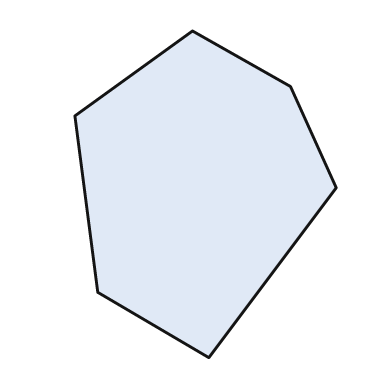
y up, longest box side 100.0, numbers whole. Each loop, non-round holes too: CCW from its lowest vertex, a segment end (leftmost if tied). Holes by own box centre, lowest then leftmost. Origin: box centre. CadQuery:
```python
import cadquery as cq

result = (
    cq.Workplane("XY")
    .moveTo(1.0, -50.0)
    .lineTo(40.0, 2.0)
    .lineTo(26.0, 33.0)
    .lineTo(-4.0, 50.0)
    .lineTo(-40.0, 24.0)
    .lineTo(-33.0, -30.0)
    .close()
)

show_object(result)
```